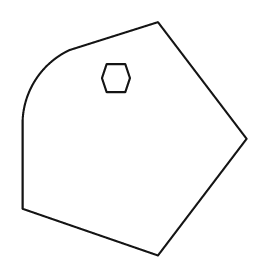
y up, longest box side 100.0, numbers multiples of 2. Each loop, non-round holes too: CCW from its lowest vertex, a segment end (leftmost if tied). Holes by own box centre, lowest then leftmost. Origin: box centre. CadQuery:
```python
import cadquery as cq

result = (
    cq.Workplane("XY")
    .moveTo(10.0, -50.0)
    .lineTo(48.0, 0.0)
    .lineTo(10.0, 50.0)
    .lineTo(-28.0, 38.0)
    .threePointArc((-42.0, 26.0), (-48.0, 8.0))
    .lineTo(-48.0, -30.0)
    .close()
    .moveTo(-12.0, 20.0)
    .lineTo(-4.0, 20.0)
    .lineTo(-2.0, 26.0)
    .lineTo(-4.0, 32.0)
    .lineTo(-12.0, 32.0)
    .lineTo(-14.0, 26.0)
    .close()
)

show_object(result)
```